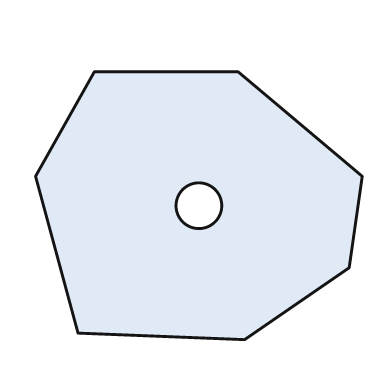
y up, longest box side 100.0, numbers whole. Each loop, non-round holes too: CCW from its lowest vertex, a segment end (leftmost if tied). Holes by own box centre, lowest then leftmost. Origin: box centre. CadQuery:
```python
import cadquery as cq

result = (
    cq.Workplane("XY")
    .moveTo(14.0, -41.0)
    .lineTo(46.0, -19.0)
    .lineTo(50.0, 9.0)
    .lineTo(12.0, 41.0)
    .lineTo(-32.0, 41.0)
    .lineTo(-50.0, 9.0)
    .lineTo(-37.0, -39.0)
    .close()
    .moveTo(0.0, 0.0)
    .circle(7.0)
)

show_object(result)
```